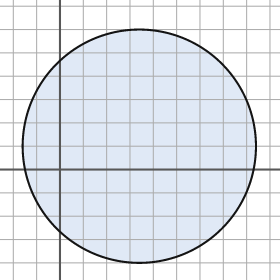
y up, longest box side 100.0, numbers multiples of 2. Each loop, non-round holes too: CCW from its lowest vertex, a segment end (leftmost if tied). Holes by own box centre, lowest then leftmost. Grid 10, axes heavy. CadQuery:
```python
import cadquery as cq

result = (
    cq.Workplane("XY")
    .moveTo(34.0, 10.0)
    .circle(50.0)
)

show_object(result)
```